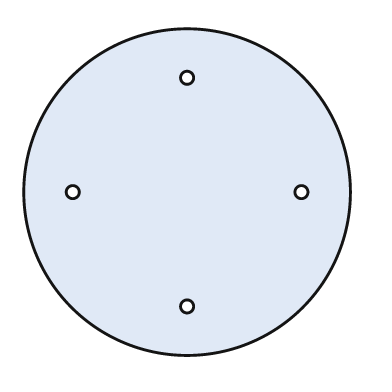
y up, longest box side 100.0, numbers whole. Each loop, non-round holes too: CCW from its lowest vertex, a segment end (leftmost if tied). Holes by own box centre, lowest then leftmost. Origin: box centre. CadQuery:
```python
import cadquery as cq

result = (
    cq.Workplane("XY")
    .moveTo(0.0, 0.0)
    .circle(50.0)
    .moveTo(0.0, -35.0)
    .circle(2.0)
    .moveTo(-35.0, 0.0)
    .circle(2.0)
    .moveTo(35.0, 0.0)
    .circle(2.0)
    .moveTo(0.0, 35.0)
    .circle(2.0)
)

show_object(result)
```